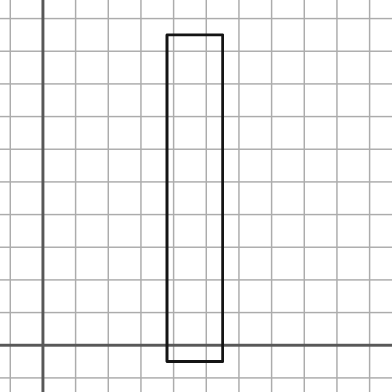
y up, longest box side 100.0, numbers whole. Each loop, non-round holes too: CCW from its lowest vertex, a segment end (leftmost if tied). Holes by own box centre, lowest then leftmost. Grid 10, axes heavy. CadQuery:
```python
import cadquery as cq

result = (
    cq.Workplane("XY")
    .moveTo(38.0, -5.0)
    .lineTo(55.0, -5.0)
    .lineTo(55.0, 95.0)
    .lineTo(38.0, 95.0)
    .close()
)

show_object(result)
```